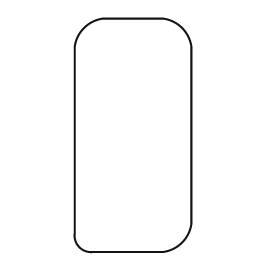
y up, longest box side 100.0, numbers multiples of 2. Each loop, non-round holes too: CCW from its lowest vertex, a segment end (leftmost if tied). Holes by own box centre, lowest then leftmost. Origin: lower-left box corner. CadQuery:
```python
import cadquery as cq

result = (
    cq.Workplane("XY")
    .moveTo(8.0, 0.0)
    .lineTo(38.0, 0.0)
    .threePointArc((46.0, 4.0), (50.0, 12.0))
    .lineTo(50.0, 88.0)
    .threePointArc((46.0, 96.0), (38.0, 100.0))
    .lineTo(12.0, 100.0)
    .threePointArc((4.0, 96.0), (0.0, 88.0))
    .lineTo(0.0, 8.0)
    .threePointArc((2.0, 2.0), (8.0, 0.0))
    .close()
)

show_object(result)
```